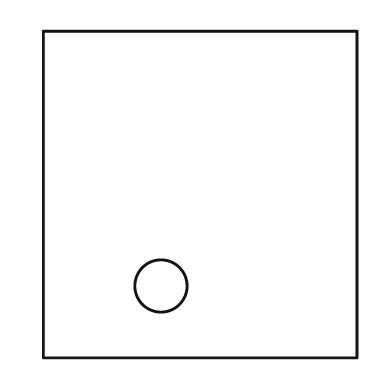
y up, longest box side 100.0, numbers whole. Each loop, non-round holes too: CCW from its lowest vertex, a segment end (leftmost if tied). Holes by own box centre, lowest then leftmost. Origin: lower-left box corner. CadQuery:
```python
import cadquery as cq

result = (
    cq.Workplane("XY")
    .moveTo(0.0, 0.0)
    .lineTo(96.0, 0.0)
    .lineTo(96.0, 100.0)
    .lineTo(0.0, 100.0)
    .close()
    .moveTo(36.0, 22.0)
    .circle(8.0)
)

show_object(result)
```